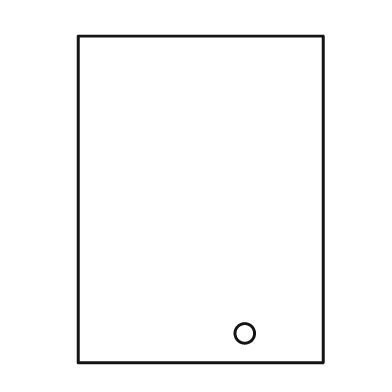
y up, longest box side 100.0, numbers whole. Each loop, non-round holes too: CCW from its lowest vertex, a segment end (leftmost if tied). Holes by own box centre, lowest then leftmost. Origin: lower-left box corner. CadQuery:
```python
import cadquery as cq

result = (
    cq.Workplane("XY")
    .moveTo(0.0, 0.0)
    .lineTo(75.0, 0.0)
    .lineTo(75.0, 100.0)
    .lineTo(0.0, 100.0)
    .close()
    .moveTo(51.0, 9.0)
    .circle(3.0)
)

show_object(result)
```